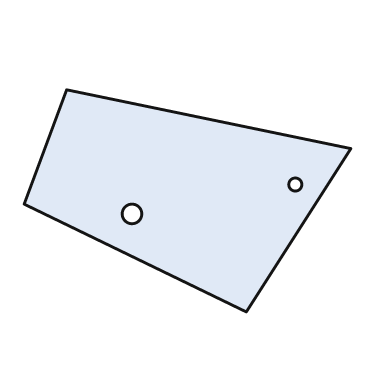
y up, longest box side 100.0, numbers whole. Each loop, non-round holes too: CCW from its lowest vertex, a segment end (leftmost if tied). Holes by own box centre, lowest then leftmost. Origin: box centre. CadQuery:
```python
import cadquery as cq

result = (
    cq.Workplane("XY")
    .moveTo(18.0, -34.0)
    .lineTo(50.0, 16.0)
    .lineTo(-37.0, 34.0)
    .lineTo(-50.0, -1.0)
    .close()
    .moveTo(-17.0, -4.0)
    .circle(3.0)
    .moveTo(33.0, 5.0)
    .circle(2.0)
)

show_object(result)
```